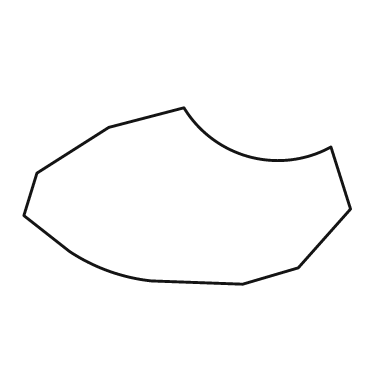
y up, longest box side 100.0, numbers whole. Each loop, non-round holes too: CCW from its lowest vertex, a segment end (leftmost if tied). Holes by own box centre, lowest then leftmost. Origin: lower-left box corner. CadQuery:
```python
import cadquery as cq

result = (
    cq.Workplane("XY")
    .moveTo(67.0, 0.0)
    .lineTo(84.0, 5.0)
    .lineTo(100.0, 23.0)
    .lineTo(94.0, 42.0)
    .threePointArc((69.0, 39.0), (49.0, 54.0))
    .lineTo(26.0, 48.0)
    .lineTo(4.0, 34.0)
    .lineTo(0.0, 21.0)
    .lineTo(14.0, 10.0)
    .threePointArc((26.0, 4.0), (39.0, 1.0))
    .close()
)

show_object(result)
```